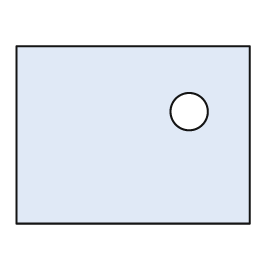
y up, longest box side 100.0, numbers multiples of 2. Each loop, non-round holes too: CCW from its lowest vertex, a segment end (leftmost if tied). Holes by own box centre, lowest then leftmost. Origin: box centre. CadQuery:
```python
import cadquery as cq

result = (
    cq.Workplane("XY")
    .moveTo(-50.0, -38.0)
    .lineTo(50.0, -38.0)
    .lineTo(50.0, 38.0)
    .lineTo(-50.0, 38.0)
    .close()
    .moveTo(24.0, 10.0)
    .circle(8.0)
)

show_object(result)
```